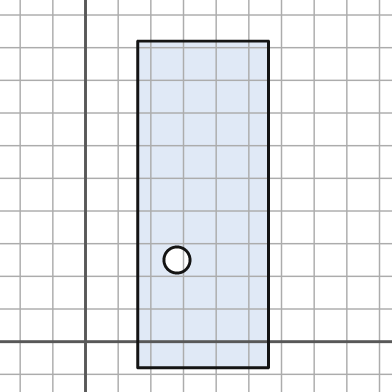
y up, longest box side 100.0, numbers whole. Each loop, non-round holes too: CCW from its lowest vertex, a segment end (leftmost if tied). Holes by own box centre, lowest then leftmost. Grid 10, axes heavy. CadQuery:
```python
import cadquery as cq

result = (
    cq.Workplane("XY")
    .moveTo(16.0, -8.0)
    .lineTo(56.0, -8.0)
    .lineTo(56.0, 92.0)
    .lineTo(16.0, 92.0)
    .close()
    .moveTo(28.0, 25.0)
    .circle(4.0)
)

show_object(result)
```